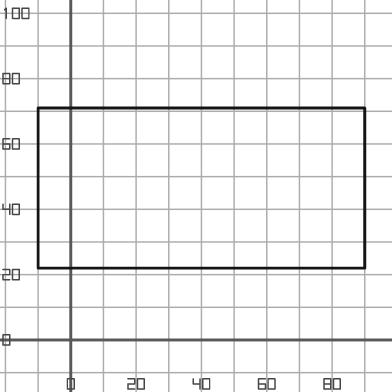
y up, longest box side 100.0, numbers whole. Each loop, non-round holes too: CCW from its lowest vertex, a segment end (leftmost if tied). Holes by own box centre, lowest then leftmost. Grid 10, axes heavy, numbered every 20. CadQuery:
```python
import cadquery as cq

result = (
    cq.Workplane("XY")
    .moveTo(-10.0, 22.0)
    .lineTo(90.0, 22.0)
    .lineTo(90.0, 71.0)
    .lineTo(-10.0, 71.0)
    .close()
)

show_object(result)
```